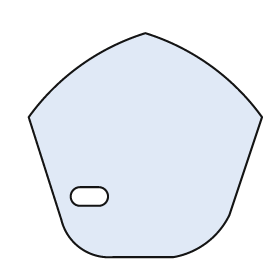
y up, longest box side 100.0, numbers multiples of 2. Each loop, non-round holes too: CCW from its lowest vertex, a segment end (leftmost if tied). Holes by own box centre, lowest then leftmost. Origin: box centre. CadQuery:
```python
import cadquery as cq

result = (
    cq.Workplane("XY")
    .moveTo(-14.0, -48.0)
    .lineTo(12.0, -48.0)
    .threePointArc((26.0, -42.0), (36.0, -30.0))
    .lineTo(50.0, 12.0)
    .threePointArc((28.0, 34.0), (0.0, 48.0))
    .threePointArc((-28.0, 34.0), (-50.0, 12.0))
    .lineTo(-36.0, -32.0)
    .threePointArc((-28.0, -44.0), (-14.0, -48.0))
    .close()
    .moveTo(-28.0, -26.0)
    .lineTo(-20.0, -26.0)
    .threePointArc((-16.0, -22.0), (-20.0, -18.0))
    .lineTo(-28.0, -18.0)
    .threePointArc((-32.0, -22.0), (-28.0, -26.0))
    .close()
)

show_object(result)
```